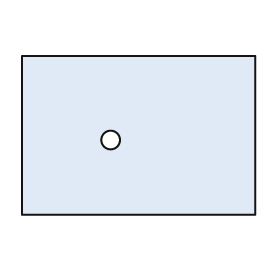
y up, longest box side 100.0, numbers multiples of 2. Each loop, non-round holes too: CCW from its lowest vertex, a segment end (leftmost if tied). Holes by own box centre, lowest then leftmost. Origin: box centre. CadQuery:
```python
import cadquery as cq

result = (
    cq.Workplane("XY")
    .moveTo(-50.0, -34.0)
    .lineTo(50.0, -34.0)
    .lineTo(50.0, 34.0)
    .lineTo(-50.0, 34.0)
    .close()
    .moveTo(-12.0, -2.0)
    .circle(4.0)
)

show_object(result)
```